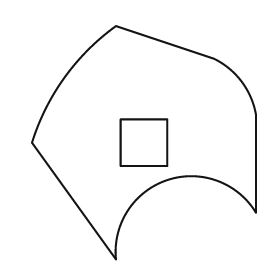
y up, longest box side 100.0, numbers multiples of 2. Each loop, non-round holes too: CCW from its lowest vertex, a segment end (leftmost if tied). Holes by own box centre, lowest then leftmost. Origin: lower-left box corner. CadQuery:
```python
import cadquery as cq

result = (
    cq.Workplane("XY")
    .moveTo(36.0, 0.0)
    .threePointArc((58.0, 34.0), (96.0, 20.0))
    .lineTo(96.0, 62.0)
    .threePointArc((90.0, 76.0), (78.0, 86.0))
    .lineTo(36.0, 100.0)
    .threePointArc((14.0, 78.0), (0.0, 50.0))
    .close()
    .moveTo(38.0, 40.0)
    .lineTo(58.0, 40.0)
    .lineTo(58.0, 60.0)
    .lineTo(38.0, 60.0)
    .close()
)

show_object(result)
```